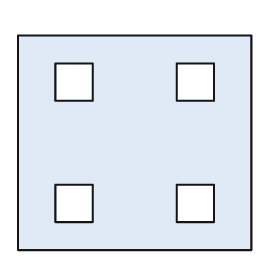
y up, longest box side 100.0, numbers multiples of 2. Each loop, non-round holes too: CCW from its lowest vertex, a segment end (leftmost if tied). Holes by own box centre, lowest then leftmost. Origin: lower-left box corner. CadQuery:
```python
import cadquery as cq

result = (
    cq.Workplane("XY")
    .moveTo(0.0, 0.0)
    .lineTo(100.0, 0.0)
    .lineTo(100.0, 92.0)
    .lineTo(0.0, 92.0)
    .close()
    .moveTo(16.0, 12.0)
    .lineTo(32.0, 12.0)
    .lineTo(32.0, 28.0)
    .lineTo(16.0, 28.0)
    .close()
    .moveTo(68.0, 12.0)
    .lineTo(84.0, 12.0)
    .lineTo(84.0, 28.0)
    .lineTo(68.0, 28.0)
    .close()
    .moveTo(16.0, 64.0)
    .lineTo(32.0, 64.0)
    .lineTo(32.0, 80.0)
    .lineTo(16.0, 80.0)
    .close()
    .moveTo(68.0, 64.0)
    .lineTo(84.0, 64.0)
    .lineTo(84.0, 80.0)
    .lineTo(68.0, 80.0)
    .close()
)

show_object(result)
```